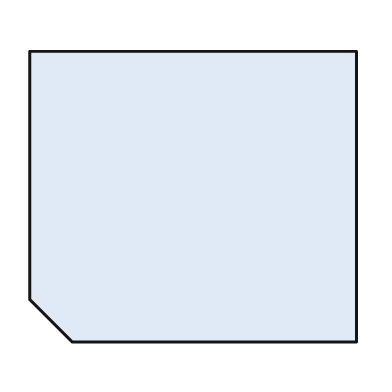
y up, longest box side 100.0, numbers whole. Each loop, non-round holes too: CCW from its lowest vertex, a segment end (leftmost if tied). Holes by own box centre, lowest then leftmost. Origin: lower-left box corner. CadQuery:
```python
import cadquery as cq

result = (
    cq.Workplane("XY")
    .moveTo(13.0, 0.0)
    .lineTo(100.0, 0.0)
    .lineTo(100.0, 89.0)
    .lineTo(0.0, 89.0)
    .lineTo(0.0, 13.0)
    .close()
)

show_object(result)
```